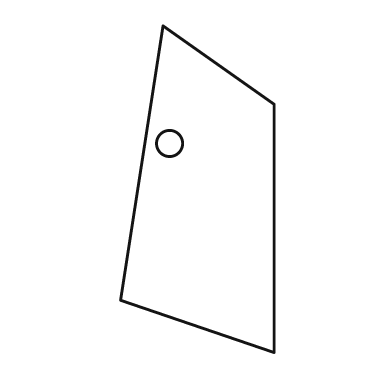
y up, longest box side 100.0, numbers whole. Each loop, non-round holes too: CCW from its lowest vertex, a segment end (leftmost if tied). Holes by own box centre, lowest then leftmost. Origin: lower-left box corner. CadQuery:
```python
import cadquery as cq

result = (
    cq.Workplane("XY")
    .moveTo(47.0, 0.0)
    .lineTo(47.0, 76.0)
    .lineTo(13.0, 100.0)
    .lineTo(0.0, 16.0)
    .close()
    .moveTo(15.0, 64.0)
    .circle(4.0)
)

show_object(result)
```